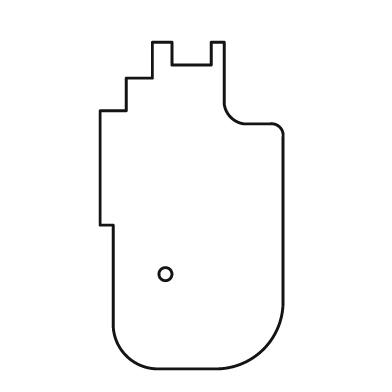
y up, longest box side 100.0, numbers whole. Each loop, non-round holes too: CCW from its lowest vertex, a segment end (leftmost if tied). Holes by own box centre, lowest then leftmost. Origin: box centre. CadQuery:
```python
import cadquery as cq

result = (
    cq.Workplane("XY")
    .moveTo(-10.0, -50.0)
    .lineTo(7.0, -50.0)
    .threePointArc((22.0, -44.0), (28.0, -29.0))
    .lineTo(28.0, 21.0)
    .threePointArc((27.0, 24.0), (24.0, 25.0))
    .lineTo(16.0, 25.0)
    .threePointArc((12.0, 27.0), (10.0, 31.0))
    .lineTo(10.0, 50.0)
    .lineTo(6.0, 50.0)
    .lineTo(6.0, 43.0)
    .lineTo(-6.0, 43.0)
    .lineTo(-6.0, 50.0)
    .lineTo(-12.0, 50.0)
    .lineTo(-12.0, 39.0)
    .lineTo(-20.0, 39.0)
    .lineTo(-20.0, 29.0)
    .lineTo(-28.0, 29.0)
    .lineTo(-28.0, -6.0)
    .lineTo(-24.0, -6.0)
    .lineTo(-24.0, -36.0)
    .threePointArc((-20.0, -46.0), (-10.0, -50.0))
    .close()
    .moveTo(-8.0, -21.0)
    .circle(2.0)
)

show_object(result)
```